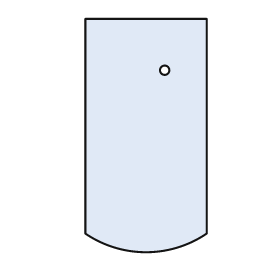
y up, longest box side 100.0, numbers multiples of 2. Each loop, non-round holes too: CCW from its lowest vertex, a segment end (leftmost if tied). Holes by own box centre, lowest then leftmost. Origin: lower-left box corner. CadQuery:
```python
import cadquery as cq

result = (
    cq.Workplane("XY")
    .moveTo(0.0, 8.0)
    .threePointArc((26.0, 0.0), (52.0, 8.0))
    .lineTo(52.0, 100.0)
    .lineTo(0.0, 100.0)
    .close()
    .moveTo(34.0, 78.0)
    .circle(2.0)
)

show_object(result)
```